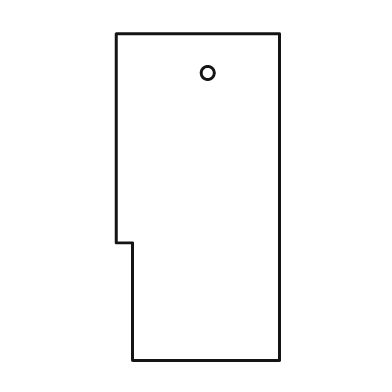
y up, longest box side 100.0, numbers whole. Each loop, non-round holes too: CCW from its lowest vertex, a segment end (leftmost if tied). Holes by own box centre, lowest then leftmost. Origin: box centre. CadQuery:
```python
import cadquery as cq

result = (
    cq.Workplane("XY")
    .moveTo(-20.0, -50.0)
    .lineTo(25.0, -50.0)
    .lineTo(25.0, 50.0)
    .lineTo(-25.0, 50.0)
    .lineTo(-25.0, -14.0)
    .lineTo(-20.0, -14.0)
    .close()
    .moveTo(3.0, 38.0)
    .circle(2.0)
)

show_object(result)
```